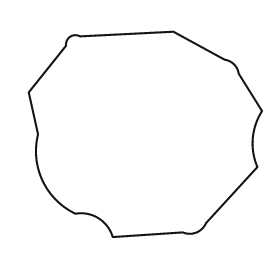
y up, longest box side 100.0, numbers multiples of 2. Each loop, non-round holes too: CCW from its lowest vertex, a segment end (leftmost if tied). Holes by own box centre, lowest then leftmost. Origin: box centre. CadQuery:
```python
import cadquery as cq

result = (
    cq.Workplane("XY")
    .moveTo(-14.0, -44.0)
    .lineTo(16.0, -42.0)
    .threePointArc((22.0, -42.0), (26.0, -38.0))
    .lineTo(48.0, -14.0)
    .threePointArc((46.0, -2.0), (50.0, 10.0))
    .lineTo(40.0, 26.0)
    .threePointArc((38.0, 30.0), (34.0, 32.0))
    .lineTo(12.0, 44.0)
    .lineTo(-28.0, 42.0)
    .threePointArc((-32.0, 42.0), (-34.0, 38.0))
    .lineTo(-50.0, 18.0)
    .lineTo(-46.0, 0.0)
    .threePointArc((-44.0, -20.0), (-30.0, -34.0))
    .threePointArc((-20.0, -36.0), (-14.0, -44.0))
    .close()
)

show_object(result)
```